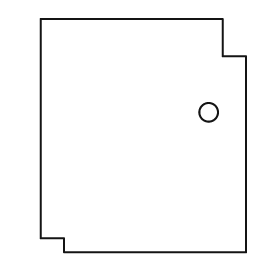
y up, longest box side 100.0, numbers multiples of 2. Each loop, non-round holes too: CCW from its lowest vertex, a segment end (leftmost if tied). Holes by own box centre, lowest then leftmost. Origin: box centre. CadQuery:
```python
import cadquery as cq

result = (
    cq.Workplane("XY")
    .moveTo(-34.0, -50.0)
    .lineTo(44.0, -50.0)
    .lineTo(44.0, 34.0)
    .lineTo(34.0, 34.0)
    .lineTo(34.0, 50.0)
    .lineTo(-44.0, 50.0)
    .lineTo(-44.0, -44.0)
    .lineTo(-34.0, -44.0)
    .close()
    .moveTo(28.0, 10.0)
    .circle(4.0)
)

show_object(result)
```